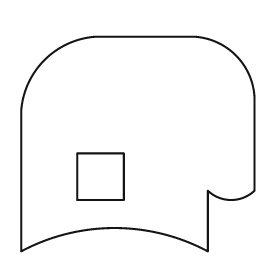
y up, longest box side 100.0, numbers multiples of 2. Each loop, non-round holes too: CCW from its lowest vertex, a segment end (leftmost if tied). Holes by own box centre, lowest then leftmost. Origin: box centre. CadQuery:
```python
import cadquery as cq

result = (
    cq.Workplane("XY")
    .moveTo(-50.0, -46.0)
    .threePointArc((-10.0, -36.0), (30.0, -46.0))
    .lineTo(30.0, -20.0)
    .threePointArc((40.0, -24.0), (50.0, -20.0))
    .lineTo(50.0, 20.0)
    .threePointArc((42.0, 38.0), (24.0, 46.0))
    .lineTo(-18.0, 46.0)
    .threePointArc((-40.0, 36.0), (-50.0, 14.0))
    .close()
    .moveTo(-26.0, -24.0)
    .lineTo(-6.0, -24.0)
    .lineTo(-6.0, -4.0)
    .lineTo(-26.0, -4.0)
    .close()
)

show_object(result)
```